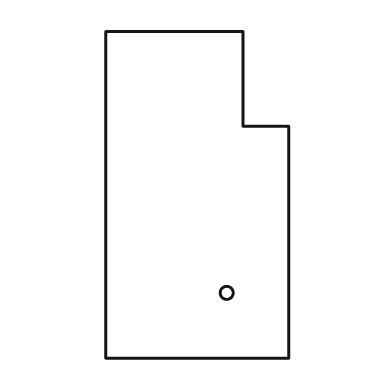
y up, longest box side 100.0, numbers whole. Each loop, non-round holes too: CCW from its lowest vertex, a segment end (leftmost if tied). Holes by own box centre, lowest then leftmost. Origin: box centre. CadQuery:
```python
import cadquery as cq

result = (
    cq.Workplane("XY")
    .moveTo(-28.0, -50.0)
    .lineTo(28.0, -50.0)
    .lineTo(28.0, 21.0)
    .lineTo(14.0, 21.0)
    .lineTo(14.0, 50.0)
    .lineTo(-28.0, 50.0)
    .close()
    .moveTo(9.0, -30.0)
    .circle(2.0)
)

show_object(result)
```